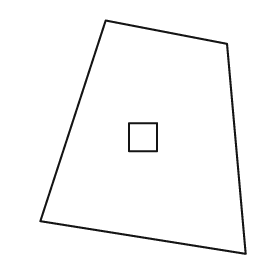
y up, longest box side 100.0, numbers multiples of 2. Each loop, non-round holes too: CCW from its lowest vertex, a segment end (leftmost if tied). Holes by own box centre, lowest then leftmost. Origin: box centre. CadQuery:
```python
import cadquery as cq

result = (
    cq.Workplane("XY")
    .moveTo(44.0, -50.0)
    .lineTo(36.0, 40.0)
    .lineTo(-16.0, 50.0)
    .lineTo(-44.0, -36.0)
    .close()
    .moveTo(-6.0, -6.0)
    .lineTo(6.0, -6.0)
    .lineTo(6.0, 6.0)
    .lineTo(-6.0, 6.0)
    .close()
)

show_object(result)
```